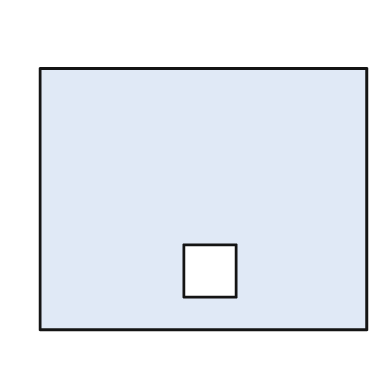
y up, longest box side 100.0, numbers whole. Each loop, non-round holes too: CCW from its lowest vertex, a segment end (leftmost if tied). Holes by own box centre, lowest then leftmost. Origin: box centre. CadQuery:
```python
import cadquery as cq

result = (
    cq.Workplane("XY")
    .moveTo(-50.0, -40.0)
    .lineTo(50.0, -40.0)
    .lineTo(50.0, 40.0)
    .lineTo(-50.0, 40.0)
    .close()
    .moveTo(-6.0, -30.0)
    .lineTo(10.0, -30.0)
    .lineTo(10.0, -14.0)
    .lineTo(-6.0, -14.0)
    .close()
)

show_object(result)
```